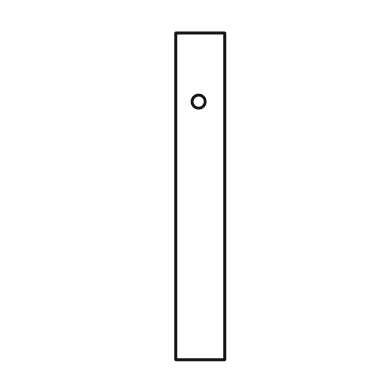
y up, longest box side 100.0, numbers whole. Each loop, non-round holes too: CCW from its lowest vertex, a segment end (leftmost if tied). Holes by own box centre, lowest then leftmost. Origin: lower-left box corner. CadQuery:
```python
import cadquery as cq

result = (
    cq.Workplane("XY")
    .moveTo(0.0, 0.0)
    .lineTo(15.0, 0.0)
    .lineTo(15.0, 100.0)
    .lineTo(0.0, 100.0)
    .close()
    .moveTo(7.0, 79.0)
    .circle(2.0)
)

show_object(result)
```